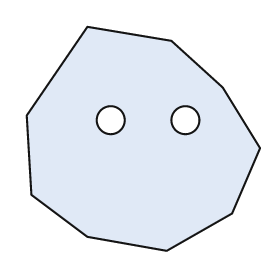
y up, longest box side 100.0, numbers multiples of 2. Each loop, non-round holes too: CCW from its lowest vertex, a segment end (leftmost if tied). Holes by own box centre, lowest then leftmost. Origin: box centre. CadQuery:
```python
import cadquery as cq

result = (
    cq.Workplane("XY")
    .moveTo(10.0, -48.0)
    .lineTo(38.0, -32.0)
    .lineTo(50.0, -4.0)
    .lineTo(34.0, 22.0)
    .lineTo(12.0, 42.0)
    .lineTo(-24.0, 48.0)
    .lineTo(-50.0, 10.0)
    .lineTo(-48.0, -24.0)
    .lineTo(-24.0, -42.0)
    .close()
    .moveTo(-14.0, 8.0)
    .circle(6.0)
    .moveTo(18.0, 8.0)
    .circle(6.0)
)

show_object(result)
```